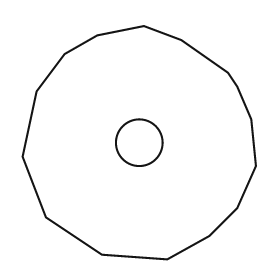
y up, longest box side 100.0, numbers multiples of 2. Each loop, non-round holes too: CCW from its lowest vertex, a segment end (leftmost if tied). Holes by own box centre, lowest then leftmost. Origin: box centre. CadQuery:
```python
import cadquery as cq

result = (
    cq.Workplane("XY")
    .moveTo(12.0, -50.0)
    .lineTo(30.0, -40.0)
    .lineTo(42.0, -28.0)
    .lineTo(50.0, -10.0)
    .lineTo(48.0, 10.0)
    .lineTo(42.0, 24.0)
    .lineTo(38.0, 30.0)
    .lineTo(18.0, 44.0)
    .lineTo(2.0, 50.0)
    .lineTo(-18.0, 46.0)
    .lineTo(-32.0, 38.0)
    .lineTo(-44.0, 22.0)
    .lineTo(-50.0, -6.0)
    .lineTo(-40.0, -32.0)
    .lineTo(-16.0, -48.0)
    .close()
    .moveTo(0.0, 0.0)
    .circle(10.0)
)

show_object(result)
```